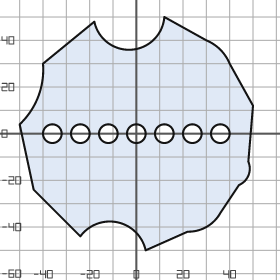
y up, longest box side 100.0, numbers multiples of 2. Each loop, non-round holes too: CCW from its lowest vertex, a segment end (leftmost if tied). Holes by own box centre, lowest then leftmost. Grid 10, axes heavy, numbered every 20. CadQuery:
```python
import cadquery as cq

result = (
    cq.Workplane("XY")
    .moveTo(4.0, -50.0)
    .lineTo(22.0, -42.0)
    .threePointArc((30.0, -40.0), (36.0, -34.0))
    .lineTo(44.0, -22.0)
    .threePointArc((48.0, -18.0), (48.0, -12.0))
    .lineTo(50.0, 12.0)
    .lineTo(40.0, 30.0)
    .threePointArc((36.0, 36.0), (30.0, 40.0))
    .lineTo(12.0, 50.0)
    .threePointArc((-2.0, 36.0), (-18.0, 48.0))
    .lineTo(-40.0, 30.0)
    .threePointArc((-42.0, 16.0), (-50.0, 4.0))
    .lineTo(-44.0, -24.0)
    .lineTo(-24.0, -44.0)
    .threePointArc((-8.0, -38.0), (4.0, -50.0))
    .close()
    .moveTo(-36.0, 0.0)
    .circle(4.0)
    .moveTo(-24.0, 0.0)
    .circle(4.0)
    .moveTo(-12.0, 0.0)
    .circle(4.0)
    .moveTo(0.0, 0.0)
    .circle(4.0)
    .moveTo(12.0, 0.0)
    .circle(4.0)
    .moveTo(24.0, 0.0)
    .circle(4.0)
    .moveTo(36.0, 0.0)
    .circle(4.0)
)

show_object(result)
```